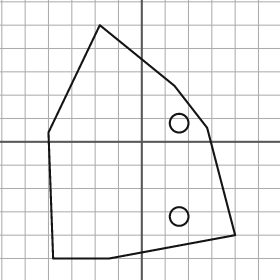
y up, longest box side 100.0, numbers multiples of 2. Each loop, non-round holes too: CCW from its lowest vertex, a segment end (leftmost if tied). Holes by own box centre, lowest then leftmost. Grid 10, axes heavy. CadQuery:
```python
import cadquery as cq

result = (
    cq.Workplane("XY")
    .moveTo(-38.0, -50.0)
    .lineTo(-14.0, -50.0)
    .lineTo(40.0, -40.0)
    .lineTo(28.0, 6.0)
    .lineTo(14.0, 24.0)
    .lineTo(-18.0, 50.0)
    .lineTo(-40.0, 4.0)
    .close()
    .moveTo(16.0, -32.0)
    .circle(4.0)
    .moveTo(16.0, 8.0)
    .circle(4.0)
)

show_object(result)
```